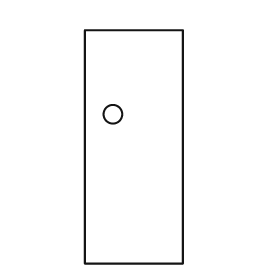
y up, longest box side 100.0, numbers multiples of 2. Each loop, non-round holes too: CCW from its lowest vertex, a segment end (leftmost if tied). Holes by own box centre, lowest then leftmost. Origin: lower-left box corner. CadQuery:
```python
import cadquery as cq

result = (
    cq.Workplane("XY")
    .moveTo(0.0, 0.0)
    .lineTo(42.0, 0.0)
    .lineTo(42.0, 100.0)
    .lineTo(0.0, 100.0)
    .close()
    .moveTo(12.0, 64.0)
    .circle(4.0)
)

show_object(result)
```